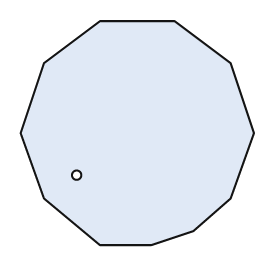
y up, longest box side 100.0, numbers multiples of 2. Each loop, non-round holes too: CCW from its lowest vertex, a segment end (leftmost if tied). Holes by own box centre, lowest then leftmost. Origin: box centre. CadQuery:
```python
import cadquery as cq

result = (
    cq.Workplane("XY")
    .moveTo(-16.0, -48.0)
    .lineTo(6.0, -48.0)
    .lineTo(24.0, -42.0)
    .lineTo(40.0, -28.0)
    .lineTo(50.0, 0.0)
    .lineTo(40.0, 30.0)
    .lineTo(16.0, 48.0)
    .lineTo(-16.0, 48.0)
    .lineTo(-40.0, 30.0)
    .lineTo(-50.0, 0.0)
    .lineTo(-40.0, -28.0)
    .close()
    .moveTo(-26.0, -18.0)
    .circle(2.0)
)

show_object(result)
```